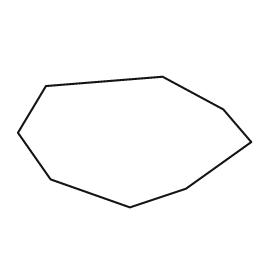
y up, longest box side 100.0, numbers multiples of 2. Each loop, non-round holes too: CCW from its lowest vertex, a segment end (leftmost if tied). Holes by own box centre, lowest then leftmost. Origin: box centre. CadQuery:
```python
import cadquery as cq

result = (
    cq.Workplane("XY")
    .moveTo(-2.0, -28.0)
    .lineTo(22.0, -20.0)
    .lineTo(50.0, 0.0)
    .lineTo(38.0, 14.0)
    .lineTo(12.0, 28.0)
    .lineTo(-38.0, 24.0)
    .lineTo(-50.0, 4.0)
    .lineTo(-36.0, -16.0)
    .close()
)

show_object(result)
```